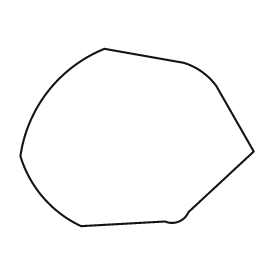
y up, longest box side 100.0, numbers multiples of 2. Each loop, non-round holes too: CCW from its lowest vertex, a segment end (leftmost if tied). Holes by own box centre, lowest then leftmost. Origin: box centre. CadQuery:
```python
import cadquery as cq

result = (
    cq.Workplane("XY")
    .moveTo(-24.0, -38.0)
    .lineTo(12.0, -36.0)
    .threePointArc((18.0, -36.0), (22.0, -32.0))
    .lineTo(50.0, -6.0)
    .lineTo(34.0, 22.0)
    .threePointArc((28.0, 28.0), (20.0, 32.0))
    .lineTo(-14.0, 38.0)
    .threePointArc((-38.0, 20.0), (-50.0, -8.0))
    .threePointArc((-40.0, -26.0), (-24.0, -38.0))
    .close()
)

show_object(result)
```